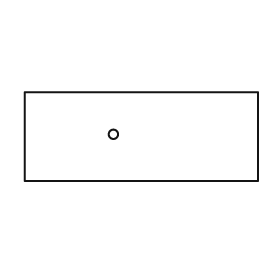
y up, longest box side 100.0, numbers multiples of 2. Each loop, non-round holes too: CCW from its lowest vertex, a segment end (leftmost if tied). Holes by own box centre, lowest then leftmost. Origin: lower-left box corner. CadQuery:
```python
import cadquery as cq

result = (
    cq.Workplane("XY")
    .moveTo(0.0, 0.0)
    .lineTo(100.0, 0.0)
    .lineTo(100.0, 38.0)
    .lineTo(0.0, 38.0)
    .close()
    .moveTo(38.0, 20.0)
    .circle(2.0)
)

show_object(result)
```